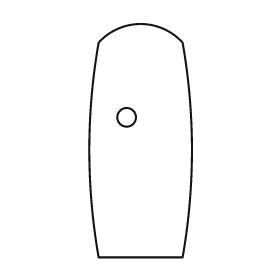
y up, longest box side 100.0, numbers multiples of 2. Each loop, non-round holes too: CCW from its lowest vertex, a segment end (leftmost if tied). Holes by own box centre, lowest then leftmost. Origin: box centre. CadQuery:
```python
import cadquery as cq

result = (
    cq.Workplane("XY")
    .moveTo(-18.0, -50.0)
    .lineTo(18.0, -50.0)
    .threePointArc((22.0, -4.0), (18.0, 42.0))
    .threePointArc((0.0, 50.0), (-18.0, 42.0))
    .threePointArc((-22.0, -4.0), (-18.0, -50.0))
    .close()
    .moveTo(-6.0, 10.0)
    .circle(4.0)
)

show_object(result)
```